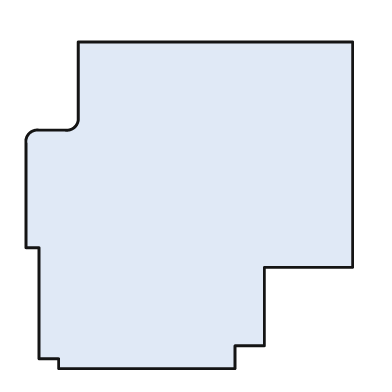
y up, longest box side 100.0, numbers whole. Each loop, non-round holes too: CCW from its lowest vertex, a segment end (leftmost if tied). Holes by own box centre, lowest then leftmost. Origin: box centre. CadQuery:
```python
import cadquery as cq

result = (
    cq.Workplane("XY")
    .moveTo(-40.0, -50.0)
    .lineTo(14.0, -50.0)
    .lineTo(14.0, -43.0)
    .lineTo(23.0, -43.0)
    .lineTo(23.0, -19.0)
    .lineTo(50.0, -19.0)
    .lineTo(50.0, 50.0)
    .lineTo(-34.0, 50.0)
    .lineTo(-34.0, 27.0)
    .threePointArc((-35.0, 24.0), (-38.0, 23.0))
    .lineTo(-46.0, 23.0)
    .threePointArc((-49.0, 22.0), (-50.0, 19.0))
    .lineTo(-50.0, -13.0)
    .lineTo(-46.0, -13.0)
    .lineTo(-46.0, -47.0)
    .lineTo(-40.0, -47.0)
    .close()
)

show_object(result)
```